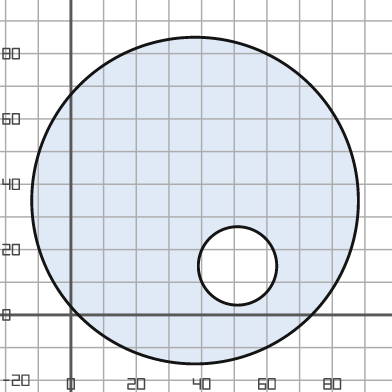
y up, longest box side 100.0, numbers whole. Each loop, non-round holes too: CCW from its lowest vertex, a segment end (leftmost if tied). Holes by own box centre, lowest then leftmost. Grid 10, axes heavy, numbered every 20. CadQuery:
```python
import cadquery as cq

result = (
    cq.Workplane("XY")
    .moveTo(38.0, 35.0)
    .circle(50.0)
    .moveTo(51.0, 15.0)
    .circle(12.0)
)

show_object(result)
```